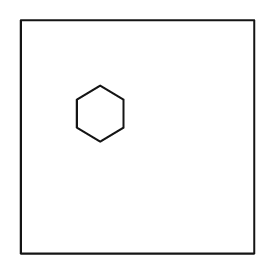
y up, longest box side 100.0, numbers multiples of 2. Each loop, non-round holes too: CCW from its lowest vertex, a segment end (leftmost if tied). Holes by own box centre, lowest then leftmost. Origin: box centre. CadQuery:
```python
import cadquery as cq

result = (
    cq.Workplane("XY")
    .moveTo(-50.0, -50.0)
    .lineTo(50.0, -50.0)
    .lineTo(50.0, 50.0)
    .lineTo(-50.0, 50.0)
    .close()
    .moveTo(-16.0, -2.0)
    .lineTo(-6.0, 4.0)
    .lineTo(-6.0, 16.0)
    .lineTo(-16.0, 22.0)
    .lineTo(-26.0, 16.0)
    .lineTo(-26.0, 4.0)
    .close()
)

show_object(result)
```